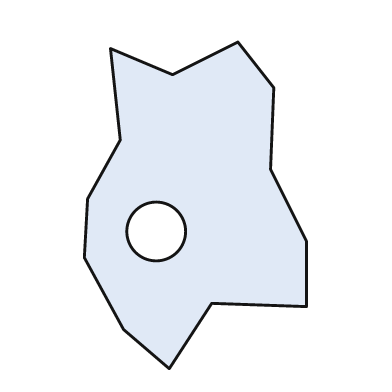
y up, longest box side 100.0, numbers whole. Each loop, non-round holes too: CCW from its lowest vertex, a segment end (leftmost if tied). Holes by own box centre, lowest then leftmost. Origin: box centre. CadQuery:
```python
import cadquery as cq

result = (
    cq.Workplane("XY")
    .moveTo(-8.0, -50.0)
    .lineTo(5.0, -30.0)
    .lineTo(34.0, -31.0)
    .lineTo(34.0, -11.0)
    .lineTo(23.0, 11.0)
    .lineTo(24.0, 36.0)
    .lineTo(13.0, 50.0)
    .lineTo(-7.0, 40.0)
    .lineTo(-26.0, 48.0)
    .lineTo(-23.0, 20.0)
    .lineTo(-33.0, 2.0)
    .lineTo(-34.0, -16.0)
    .lineTo(-22.0, -38.0)
    .close()
    .moveTo(-12.0, -8.0)
    .circle(9.0)
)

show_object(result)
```